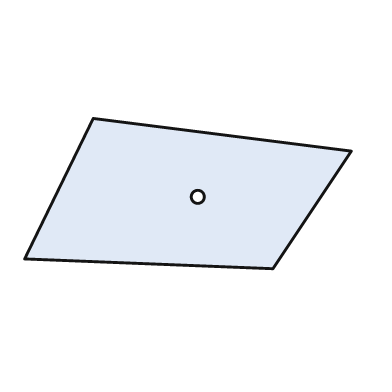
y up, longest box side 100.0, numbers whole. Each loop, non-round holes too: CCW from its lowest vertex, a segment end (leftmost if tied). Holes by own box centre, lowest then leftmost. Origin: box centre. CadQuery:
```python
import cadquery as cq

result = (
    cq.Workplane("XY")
    .moveTo(26.0, -23.0)
    .lineTo(50.0, 13.0)
    .lineTo(-29.0, 23.0)
    .lineTo(-50.0, -20.0)
    .close()
    .moveTo(3.0, -1.0)
    .circle(2.0)
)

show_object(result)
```